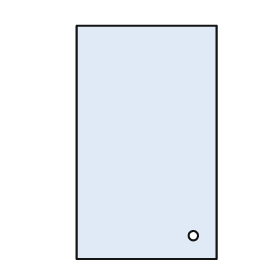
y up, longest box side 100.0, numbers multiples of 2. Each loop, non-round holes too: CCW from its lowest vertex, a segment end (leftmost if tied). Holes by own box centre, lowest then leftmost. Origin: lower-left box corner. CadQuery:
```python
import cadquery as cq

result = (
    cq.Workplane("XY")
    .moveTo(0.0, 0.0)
    .lineTo(60.0, 0.0)
    .lineTo(60.0, 100.0)
    .lineTo(0.0, 100.0)
    .close()
    .moveTo(50.0, 10.0)
    .circle(2.0)
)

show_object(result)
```